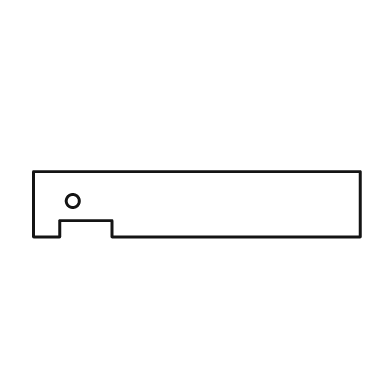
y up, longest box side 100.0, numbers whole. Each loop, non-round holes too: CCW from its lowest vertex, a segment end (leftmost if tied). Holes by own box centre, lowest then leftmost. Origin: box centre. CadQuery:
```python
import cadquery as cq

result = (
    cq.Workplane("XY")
    .moveTo(-50.0, -10.0)
    .lineTo(-42.0, -10.0)
    .lineTo(-42.0, -5.0)
    .lineTo(-26.0, -5.0)
    .lineTo(-26.0, -10.0)
    .lineTo(50.0, -10.0)
    .lineTo(50.0, 10.0)
    .lineTo(-50.0, 10.0)
    .close()
    .moveTo(-38.0, 1.0)
    .circle(2.0)
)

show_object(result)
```